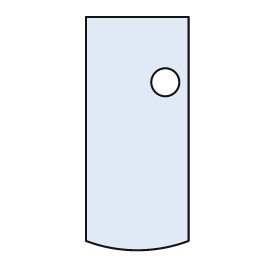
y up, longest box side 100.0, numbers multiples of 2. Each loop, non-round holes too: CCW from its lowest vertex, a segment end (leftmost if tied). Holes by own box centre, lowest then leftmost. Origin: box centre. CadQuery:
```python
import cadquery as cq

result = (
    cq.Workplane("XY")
    .moveTo(-22.0, -46.0)
    .threePointArc((0.0, -50.0), (22.0, -46.0))
    .lineTo(22.0, 50.0)
    .lineTo(-22.0, 50.0)
    .close()
    .moveTo(12.0, 22.0)
    .circle(6.0)
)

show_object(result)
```